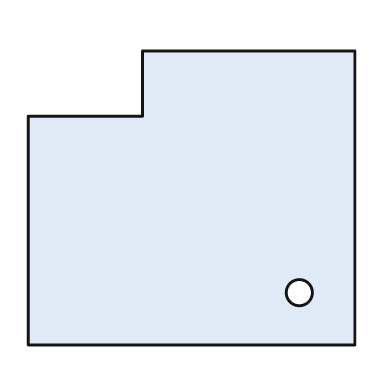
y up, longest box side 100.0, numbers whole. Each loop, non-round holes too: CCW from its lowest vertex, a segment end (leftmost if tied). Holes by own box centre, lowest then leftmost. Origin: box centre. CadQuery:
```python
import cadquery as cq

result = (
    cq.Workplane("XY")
    .moveTo(-50.0, -45.0)
    .lineTo(50.0, -45.0)
    .lineTo(50.0, 45.0)
    .lineTo(-15.0, 45.0)
    .lineTo(-15.0, 25.0)
    .lineTo(-50.0, 25.0)
    .close()
    .moveTo(33.0, -29.0)
    .circle(4.0)
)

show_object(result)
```